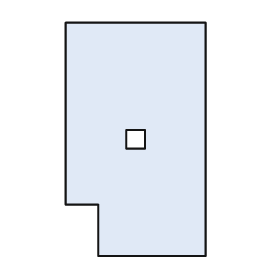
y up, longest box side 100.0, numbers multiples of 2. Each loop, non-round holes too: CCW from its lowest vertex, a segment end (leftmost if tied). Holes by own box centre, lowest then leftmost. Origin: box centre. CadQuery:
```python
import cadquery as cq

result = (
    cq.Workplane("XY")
    .moveTo(-16.0, -50.0)
    .lineTo(30.0, -50.0)
    .lineTo(30.0, 50.0)
    .lineTo(-30.0, 50.0)
    .lineTo(-30.0, -28.0)
    .lineTo(-16.0, -28.0)
    .close()
    .moveTo(-4.0, -4.0)
    .lineTo(4.0, -4.0)
    .lineTo(4.0, 4.0)
    .lineTo(-4.0, 4.0)
    .close()
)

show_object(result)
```